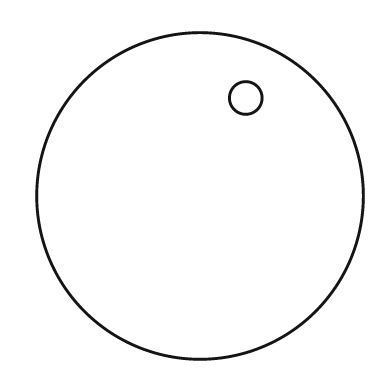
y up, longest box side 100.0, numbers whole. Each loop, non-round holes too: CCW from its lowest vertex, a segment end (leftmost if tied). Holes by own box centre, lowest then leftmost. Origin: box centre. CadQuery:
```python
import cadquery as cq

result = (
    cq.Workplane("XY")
    .moveTo(0.0, 0.0)
    .circle(50.0)
    .moveTo(14.0, 30.0)
    .circle(5.0)
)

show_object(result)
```